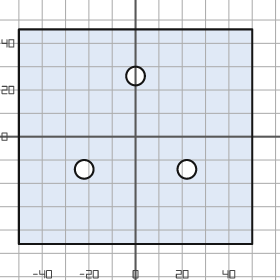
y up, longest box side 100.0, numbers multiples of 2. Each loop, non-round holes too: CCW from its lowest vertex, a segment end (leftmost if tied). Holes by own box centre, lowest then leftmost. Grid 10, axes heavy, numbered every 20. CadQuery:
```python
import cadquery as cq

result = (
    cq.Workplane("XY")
    .moveTo(-50.0, -46.0)
    .lineTo(50.0, -46.0)
    .lineTo(50.0, 46.0)
    .lineTo(-50.0, 46.0)
    .close()
    .moveTo(-22.0, -14.0)
    .circle(4.0)
    .moveTo(22.0, -14.0)
    .circle(4.0)
    .moveTo(0.0, 26.0)
    .circle(4.0)
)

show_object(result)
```